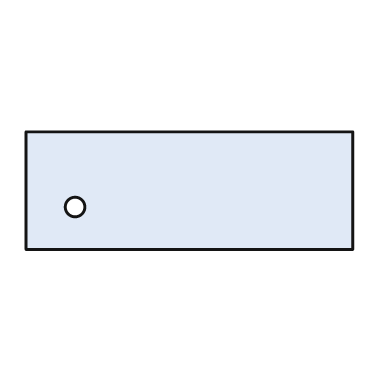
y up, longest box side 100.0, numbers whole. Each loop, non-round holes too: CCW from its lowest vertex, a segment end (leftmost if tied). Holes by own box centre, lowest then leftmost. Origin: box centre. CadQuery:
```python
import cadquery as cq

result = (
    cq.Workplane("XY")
    .moveTo(-50.0, -18.0)
    .lineTo(50.0, -18.0)
    .lineTo(50.0, 18.0)
    .lineTo(-50.0, 18.0)
    .close()
    .moveTo(-35.0, -5.0)
    .circle(3.0)
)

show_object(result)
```